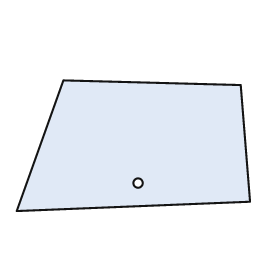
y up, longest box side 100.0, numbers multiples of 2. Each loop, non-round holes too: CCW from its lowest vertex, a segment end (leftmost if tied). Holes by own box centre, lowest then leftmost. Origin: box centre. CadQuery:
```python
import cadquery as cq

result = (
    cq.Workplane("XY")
    .moveTo(-50.0, -28.0)
    .lineTo(50.0, -24.0)
    .lineTo(46.0, 26.0)
    .lineTo(-30.0, 28.0)
    .close()
    .moveTo(2.0, -16.0)
    .circle(2.0)
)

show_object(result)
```